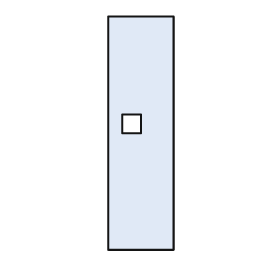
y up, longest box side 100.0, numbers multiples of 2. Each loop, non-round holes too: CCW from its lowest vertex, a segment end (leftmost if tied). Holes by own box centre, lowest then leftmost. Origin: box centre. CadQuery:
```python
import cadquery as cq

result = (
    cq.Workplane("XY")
    .moveTo(-14.0, -50.0)
    .lineTo(14.0, -50.0)
    .lineTo(14.0, 50.0)
    .lineTo(-14.0, 50.0)
    .close()
    .moveTo(-8.0, 0.0)
    .lineTo(0.0, 0.0)
    .lineTo(0.0, 8.0)
    .lineTo(-8.0, 8.0)
    .close()
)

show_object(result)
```